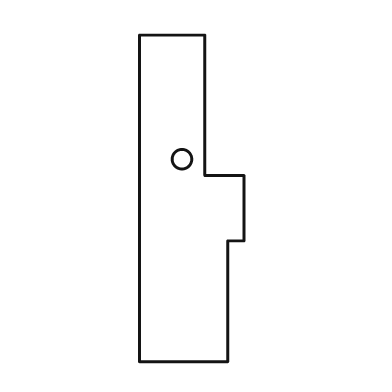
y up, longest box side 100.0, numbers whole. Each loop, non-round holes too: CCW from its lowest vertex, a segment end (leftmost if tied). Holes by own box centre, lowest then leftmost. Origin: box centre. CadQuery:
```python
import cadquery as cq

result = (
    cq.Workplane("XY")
    .moveTo(-16.0, -50.0)
    .lineTo(11.0, -50.0)
    .lineTo(11.0, -13.0)
    .lineTo(16.0, -13.0)
    .lineTo(16.0, 7.0)
    .lineTo(4.0, 7.0)
    .lineTo(4.0, 50.0)
    .lineTo(-16.0, 50.0)
    .close()
    .moveTo(-3.0, 12.0)
    .circle(3.0)
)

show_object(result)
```